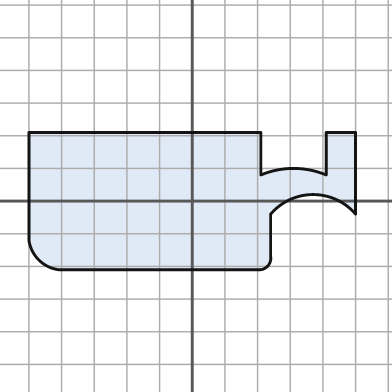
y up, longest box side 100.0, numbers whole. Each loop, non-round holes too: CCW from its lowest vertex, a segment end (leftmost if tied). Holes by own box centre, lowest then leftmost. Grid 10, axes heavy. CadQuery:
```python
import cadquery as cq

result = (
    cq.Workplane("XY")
    .moveTo(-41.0, -21.0)
    .lineTo(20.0, -21.0)
    .threePointArc((23.0, -20.0), (24.0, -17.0))
    .lineTo(24.0, -4.0)
    .threePointArc((37.0, 2.0), (50.0, -4.0))
    .lineTo(50.0, 21.0)
    .lineTo(41.0, 21.0)
    .lineTo(41.0, 8.0)
    .threePointArc((31.0, 10.0), (21.0, 8.0))
    .lineTo(21.0, 21.0)
    .lineTo(-50.0, 21.0)
    .lineTo(-50.0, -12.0)
    .threePointArc((-47.0, -18.0), (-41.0, -21.0))
    .close()
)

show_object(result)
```